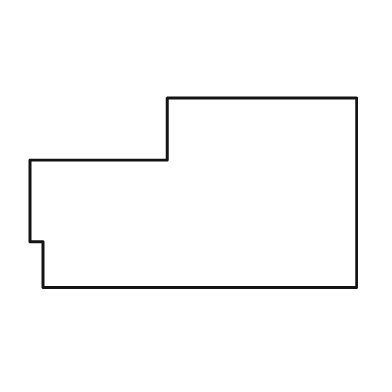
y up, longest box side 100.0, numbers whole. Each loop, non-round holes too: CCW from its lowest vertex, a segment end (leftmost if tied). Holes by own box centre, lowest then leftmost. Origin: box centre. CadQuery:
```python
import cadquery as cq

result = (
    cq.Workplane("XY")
    .moveTo(-46.0, -29.0)
    .lineTo(50.0, -29.0)
    .lineTo(50.0, 29.0)
    .lineTo(-8.0, 29.0)
    .lineTo(-8.0, 10.0)
    .lineTo(-50.0, 10.0)
    .lineTo(-50.0, -15.0)
    .lineTo(-46.0, -15.0)
    .close()
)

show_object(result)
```